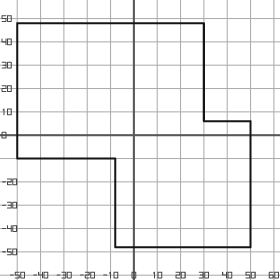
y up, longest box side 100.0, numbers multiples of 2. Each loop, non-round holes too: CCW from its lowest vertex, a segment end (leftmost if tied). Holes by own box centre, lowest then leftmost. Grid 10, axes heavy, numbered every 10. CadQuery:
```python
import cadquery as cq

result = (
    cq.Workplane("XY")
    .moveTo(-8.0, -48.0)
    .lineTo(50.0, -48.0)
    .lineTo(50.0, 6.0)
    .lineTo(30.0, 6.0)
    .lineTo(30.0, 48.0)
    .lineTo(-50.0, 48.0)
    .lineTo(-50.0, -10.0)
    .lineTo(-8.0, -10.0)
    .close()
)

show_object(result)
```